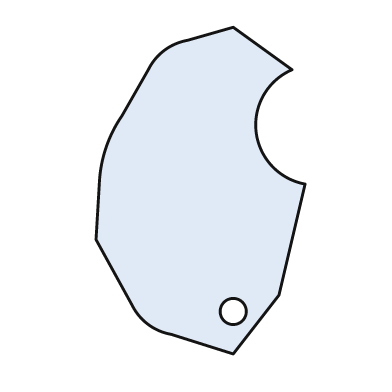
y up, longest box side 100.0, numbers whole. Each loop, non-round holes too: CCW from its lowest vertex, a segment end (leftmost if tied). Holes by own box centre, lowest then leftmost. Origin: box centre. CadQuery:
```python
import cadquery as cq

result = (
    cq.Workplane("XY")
    .moveTo(10.0, -50.0)
    .lineTo(24.0, -32.0)
    .lineTo(32.0, 2.0)
    .threePointArc((17.0, 18.0), (28.0, 37.0))
    .lineTo(10.0, 50.0)
    .lineTo(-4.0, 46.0)
    .threePointArc((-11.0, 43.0), (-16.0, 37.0))
    .lineTo(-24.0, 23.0)
    .threePointArc((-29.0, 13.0), (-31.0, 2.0))
    .lineTo(-32.0, -15.0)
    .lineTo(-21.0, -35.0)
    .threePointArc((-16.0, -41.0), (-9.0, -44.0))
    .close()
    .moveTo(10.0, -37.0)
    .circle(4.0)
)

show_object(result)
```